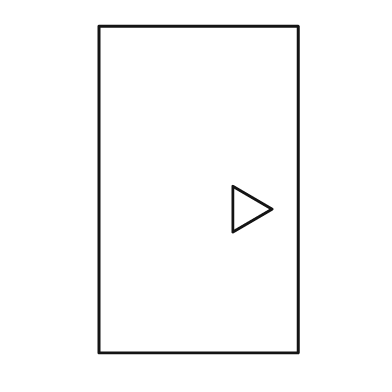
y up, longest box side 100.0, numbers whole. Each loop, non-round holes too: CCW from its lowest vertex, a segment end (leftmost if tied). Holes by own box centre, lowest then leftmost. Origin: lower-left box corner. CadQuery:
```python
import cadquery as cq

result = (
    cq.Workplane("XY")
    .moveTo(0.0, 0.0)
    .lineTo(61.0, 0.0)
    .lineTo(61.0, 100.0)
    .lineTo(0.0, 100.0)
    .close()
    .moveTo(41.0, 37.0)
    .lineTo(53.0, 44.0)
    .lineTo(41.0, 51.0)
    .close()
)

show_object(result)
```